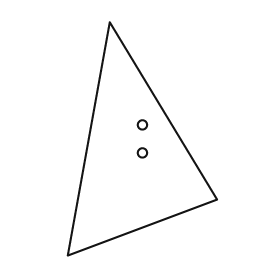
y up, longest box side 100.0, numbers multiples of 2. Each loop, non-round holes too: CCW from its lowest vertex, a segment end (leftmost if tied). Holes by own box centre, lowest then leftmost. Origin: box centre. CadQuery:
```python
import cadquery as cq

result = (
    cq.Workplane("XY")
    .moveTo(-32.0, -50.0)
    .lineTo(32.0, -26.0)
    .lineTo(-14.0, 50.0)
    .close()
    .moveTo(0.0, -6.0)
    .circle(2.0)
    .moveTo(0.0, 6.0)
    .circle(2.0)
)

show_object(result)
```